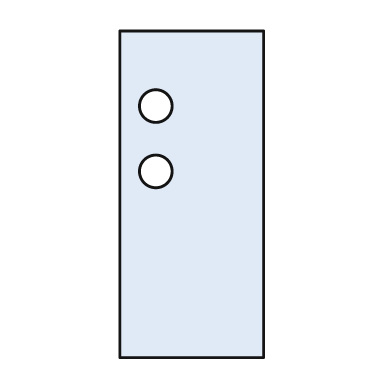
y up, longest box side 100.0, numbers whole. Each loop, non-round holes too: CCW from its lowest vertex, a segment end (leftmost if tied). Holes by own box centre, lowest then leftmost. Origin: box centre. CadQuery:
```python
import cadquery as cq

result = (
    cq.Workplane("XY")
    .moveTo(-22.0, -50.0)
    .lineTo(22.0, -50.0)
    .lineTo(22.0, 50.0)
    .lineTo(-22.0, 50.0)
    .close()
    .moveTo(-11.0, 7.0)
    .circle(5.0)
    .moveTo(-11.0, 27.0)
    .circle(5.0)
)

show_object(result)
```